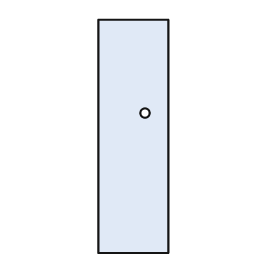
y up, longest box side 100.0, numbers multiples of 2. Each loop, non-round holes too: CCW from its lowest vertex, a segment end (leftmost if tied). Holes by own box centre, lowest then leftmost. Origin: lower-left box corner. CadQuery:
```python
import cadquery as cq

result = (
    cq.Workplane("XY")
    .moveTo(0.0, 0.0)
    .lineTo(30.0, 0.0)
    .lineTo(30.0, 100.0)
    .lineTo(0.0, 100.0)
    .close()
    .moveTo(20.0, 60.0)
    .circle(2.0)
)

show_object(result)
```